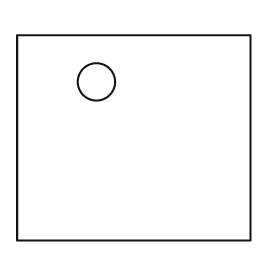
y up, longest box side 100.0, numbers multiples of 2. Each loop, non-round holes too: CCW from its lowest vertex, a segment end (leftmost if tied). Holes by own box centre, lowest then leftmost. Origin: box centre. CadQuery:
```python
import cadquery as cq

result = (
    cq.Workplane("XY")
    .moveTo(-50.0, -44.0)
    .lineTo(50.0, -44.0)
    .lineTo(50.0, 44.0)
    .lineTo(-50.0, 44.0)
    .close()
    .moveTo(-16.0, 24.0)
    .circle(8.0)
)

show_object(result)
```